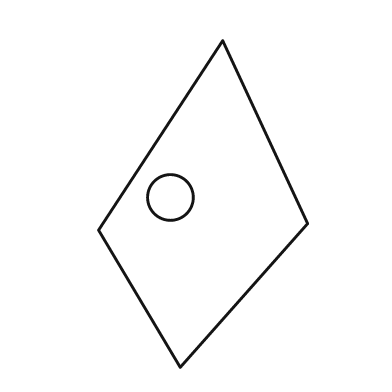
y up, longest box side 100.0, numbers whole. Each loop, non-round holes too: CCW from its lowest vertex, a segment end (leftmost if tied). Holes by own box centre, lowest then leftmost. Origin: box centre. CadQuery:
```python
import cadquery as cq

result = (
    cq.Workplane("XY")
    .moveTo(-7.0, -50.0)
    .lineTo(32.0, -6.0)
    .lineTo(6.0, 50.0)
    .lineTo(-32.0, -8.0)
    .close()
    .moveTo(-10.0, 2.0)
    .circle(7.0)
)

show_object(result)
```